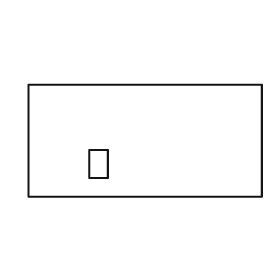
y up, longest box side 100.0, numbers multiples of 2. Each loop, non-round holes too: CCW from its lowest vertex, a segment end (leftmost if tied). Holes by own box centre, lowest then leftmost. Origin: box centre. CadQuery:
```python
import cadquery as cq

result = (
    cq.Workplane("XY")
    .moveTo(-50.0, -24.0)
    .lineTo(50.0, -24.0)
    .lineTo(50.0, 24.0)
    .lineTo(-50.0, 24.0)
    .close()
    .moveTo(-24.0, -16.0)
    .lineTo(-16.0, -16.0)
    .lineTo(-16.0, -4.0)
    .lineTo(-24.0, -4.0)
    .close()
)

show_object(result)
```